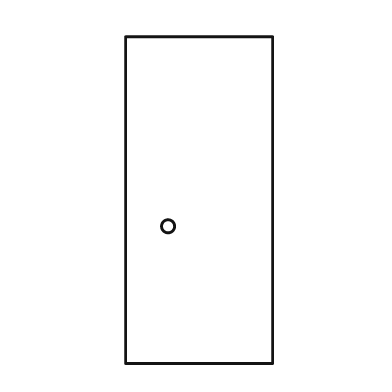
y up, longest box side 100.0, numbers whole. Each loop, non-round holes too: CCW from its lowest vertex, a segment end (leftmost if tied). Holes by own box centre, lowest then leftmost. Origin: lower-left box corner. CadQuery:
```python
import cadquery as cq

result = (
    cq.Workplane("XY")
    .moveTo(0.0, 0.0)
    .lineTo(45.0, 0.0)
    .lineTo(45.0, 100.0)
    .lineTo(0.0, 100.0)
    .close()
    .moveTo(13.0, 42.0)
    .circle(2.0)
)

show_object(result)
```